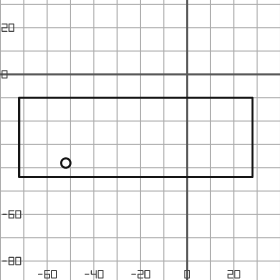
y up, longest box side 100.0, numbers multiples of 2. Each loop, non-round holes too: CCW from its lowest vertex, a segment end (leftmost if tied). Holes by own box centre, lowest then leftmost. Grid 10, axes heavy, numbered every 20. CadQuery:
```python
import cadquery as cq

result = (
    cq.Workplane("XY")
    .moveTo(-72.0, -44.0)
    .lineTo(28.0, -44.0)
    .lineTo(28.0, -10.0)
    .lineTo(-72.0, -10.0)
    .close()
    .moveTo(-52.0, -38.0)
    .circle(2.0)
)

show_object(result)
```